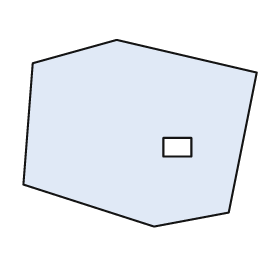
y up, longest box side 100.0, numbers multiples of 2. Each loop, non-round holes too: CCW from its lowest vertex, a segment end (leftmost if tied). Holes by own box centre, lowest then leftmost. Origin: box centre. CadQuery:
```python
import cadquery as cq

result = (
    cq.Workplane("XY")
    .moveTo(6.0, -40.0)
    .lineTo(38.0, -34.0)
    .lineTo(50.0, 26.0)
    .lineTo(-10.0, 40.0)
    .lineTo(-46.0, 30.0)
    .lineTo(-50.0, -22.0)
    .close()
    .moveTo(10.0, -10.0)
    .lineTo(22.0, -10.0)
    .lineTo(22.0, -2.0)
    .lineTo(10.0, -2.0)
    .close()
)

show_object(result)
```